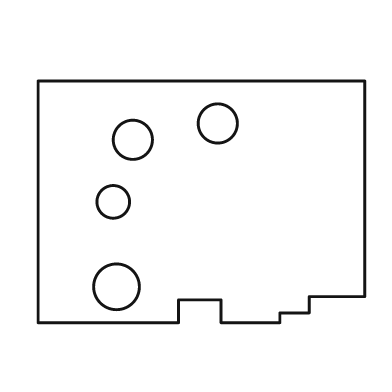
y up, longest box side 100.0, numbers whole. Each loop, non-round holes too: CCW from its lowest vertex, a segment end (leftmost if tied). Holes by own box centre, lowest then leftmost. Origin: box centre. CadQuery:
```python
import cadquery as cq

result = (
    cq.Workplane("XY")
    .moveTo(-50.0, -37.0)
    .lineTo(-7.0, -37.0)
    .lineTo(-7.0, -30.0)
    .lineTo(6.0, -30.0)
    .lineTo(6.0, -37.0)
    .lineTo(24.0, -37.0)
    .lineTo(24.0, -34.0)
    .lineTo(33.0, -34.0)
    .lineTo(33.0, -29.0)
    .lineTo(50.0, -29.0)
    .lineTo(50.0, 37.0)
    .lineTo(-50.0, 37.0)
    .close()
    .moveTo(-26.0, -26.0)
    .circle(7.0)
    .moveTo(-27.0, 0.0)
    .circle(5.0)
    .moveTo(-21.0, 19.0)
    .circle(6.0)
    .moveTo(5.0, 24.0)
    .circle(6.0)
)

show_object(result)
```